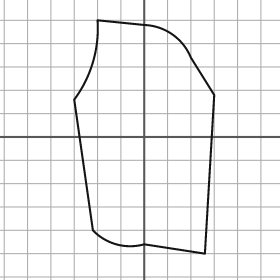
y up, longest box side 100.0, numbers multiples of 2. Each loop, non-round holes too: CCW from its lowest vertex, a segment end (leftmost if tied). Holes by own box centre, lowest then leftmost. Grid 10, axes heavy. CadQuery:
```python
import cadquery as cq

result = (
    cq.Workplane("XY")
    .moveTo(26.0, -50.0)
    .lineTo(30.0, 18.0)
    .lineTo(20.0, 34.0)
    .threePointArc((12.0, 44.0), (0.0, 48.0))
    .lineTo(-20.0, 50.0)
    .threePointArc((-22.0, 32.0), (-30.0, 16.0))
    .lineTo(-22.0, -40.0)
    .threePointArc((-12.0, -46.0), (0.0, -46.0))
    .close()
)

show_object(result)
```